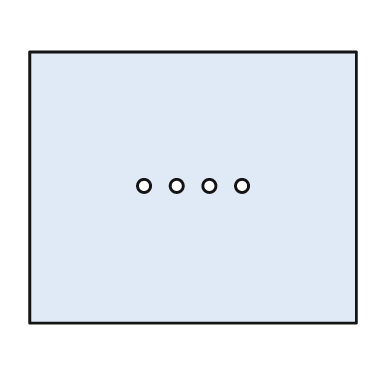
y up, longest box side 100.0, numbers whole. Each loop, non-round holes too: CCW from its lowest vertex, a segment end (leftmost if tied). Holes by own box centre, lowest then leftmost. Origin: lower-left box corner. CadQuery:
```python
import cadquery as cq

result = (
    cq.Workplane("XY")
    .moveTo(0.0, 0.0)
    .lineTo(100.0, 0.0)
    .lineTo(100.0, 83.0)
    .lineTo(0.0, 83.0)
    .close()
    .moveTo(35.0, 42.0)
    .circle(2.0)
    .moveTo(45.0, 42.0)
    .circle(2.0)
    .moveTo(55.0, 42.0)
    .circle(2.0)
    .moveTo(65.0, 42.0)
    .circle(2.0)
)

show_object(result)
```